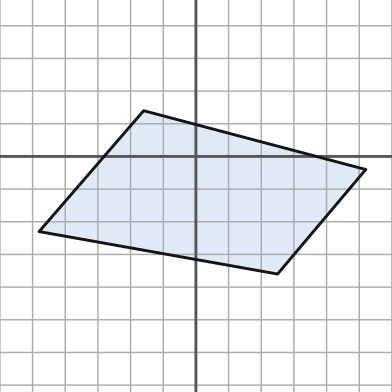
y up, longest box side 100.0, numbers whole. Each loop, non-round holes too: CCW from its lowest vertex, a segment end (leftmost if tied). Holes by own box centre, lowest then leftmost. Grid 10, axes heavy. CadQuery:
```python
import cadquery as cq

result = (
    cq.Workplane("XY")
    .moveTo(25.0, -36.0)
    .lineTo(52.0, -4.0)
    .lineTo(-16.0, 14.0)
    .lineTo(-48.0, -23.0)
    .close()
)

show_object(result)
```